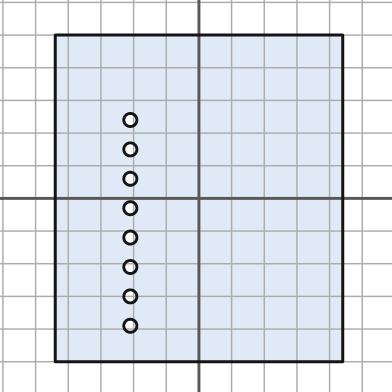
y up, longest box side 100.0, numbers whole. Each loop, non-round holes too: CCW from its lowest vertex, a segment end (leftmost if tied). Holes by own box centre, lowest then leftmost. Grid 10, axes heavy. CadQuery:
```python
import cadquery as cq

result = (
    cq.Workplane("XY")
    .moveTo(-44.0, -50.0)
    .lineTo(44.0, -50.0)
    .lineTo(44.0, 50.0)
    .lineTo(-44.0, 50.0)
    .close()
    .moveTo(-21.0, -39.0)
    .circle(2.0)
    .moveTo(-21.0, -30.0)
    .circle(2.0)
    .moveTo(-21.0, -21.0)
    .circle(2.0)
    .moveTo(-21.0, -12.0)
    .circle(2.0)
    .moveTo(-21.0, -3.0)
    .circle(2.0)
    .moveTo(-21.0, 6.0)
    .circle(2.0)
    .moveTo(-21.0, 15.0)
    .circle(2.0)
    .moveTo(-21.0, 24.0)
    .circle(2.0)
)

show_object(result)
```